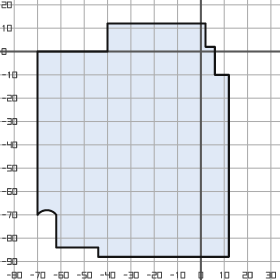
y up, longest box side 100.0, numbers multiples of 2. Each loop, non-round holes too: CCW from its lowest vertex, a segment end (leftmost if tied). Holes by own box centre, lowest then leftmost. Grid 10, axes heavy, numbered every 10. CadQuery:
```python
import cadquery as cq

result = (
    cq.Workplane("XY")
    .moveTo(-44.0, -88.0)
    .lineTo(12.0, -88.0)
    .lineTo(12.0, -10.0)
    .lineTo(6.0, -10.0)
    .lineTo(6.0, 2.0)
    .lineTo(2.0, 2.0)
    .lineTo(2.0, 12.0)
    .lineTo(-40.0, 12.0)
    .lineTo(-40.0, 0.0)
    .lineTo(-70.0, 0.0)
    .lineTo(-70.0, -70.0)
    .threePointArc((-66.0, -68.0), (-62.0, -70.0))
    .lineTo(-62.0, -84.0)
    .lineTo(-44.0, -84.0)
    .close()
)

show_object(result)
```